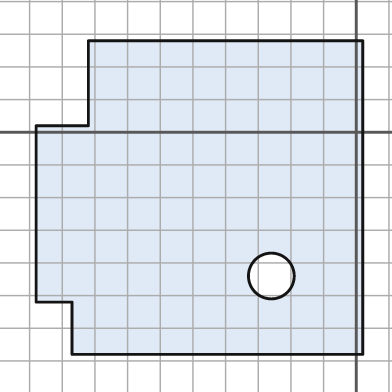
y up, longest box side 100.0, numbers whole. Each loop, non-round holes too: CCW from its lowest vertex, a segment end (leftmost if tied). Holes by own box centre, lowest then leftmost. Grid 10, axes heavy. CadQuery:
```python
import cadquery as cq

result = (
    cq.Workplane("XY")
    .moveTo(-87.0, -68.0)
    .lineTo(2.0, -68.0)
    .lineTo(2.0, 28.0)
    .lineTo(-82.0, 28.0)
    .lineTo(-82.0, 2.0)
    .lineTo(-98.0, 2.0)
    .lineTo(-98.0, -52.0)
    .lineTo(-87.0, -52.0)
    .close()
    .moveTo(-26.0, -44.0)
    .circle(7.0)
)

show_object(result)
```